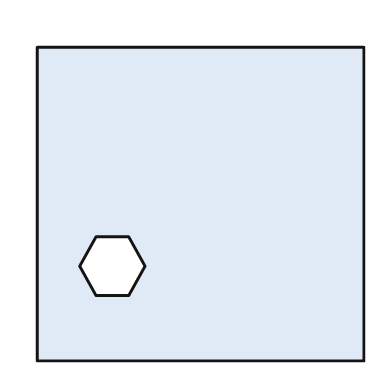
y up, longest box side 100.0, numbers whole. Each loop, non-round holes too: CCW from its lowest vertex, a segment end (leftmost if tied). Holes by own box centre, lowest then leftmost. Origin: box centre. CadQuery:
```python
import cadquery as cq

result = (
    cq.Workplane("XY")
    .moveTo(-50.0, -48.0)
    .lineTo(50.0, -48.0)
    .lineTo(50.0, 48.0)
    .lineTo(-50.0, 48.0)
    .close()
    .moveTo(-32.0, -28.0)
    .lineTo(-22.0, -28.0)
    .lineTo(-17.0, -19.0)
    .lineTo(-22.0, -10.0)
    .lineTo(-32.0, -10.0)
    .lineTo(-37.0, -19.0)
    .close()
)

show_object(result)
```